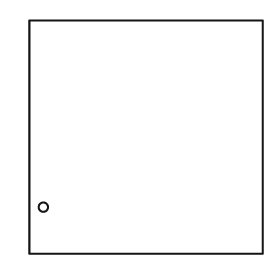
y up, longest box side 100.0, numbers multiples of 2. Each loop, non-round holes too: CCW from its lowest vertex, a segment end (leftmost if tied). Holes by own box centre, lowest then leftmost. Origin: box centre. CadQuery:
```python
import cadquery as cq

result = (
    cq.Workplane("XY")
    .moveTo(-50.0, -50.0)
    .lineTo(50.0, -50.0)
    .lineTo(50.0, 50.0)
    .lineTo(-50.0, 50.0)
    .close()
    .moveTo(-44.0, -30.0)
    .circle(2.0)
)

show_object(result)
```